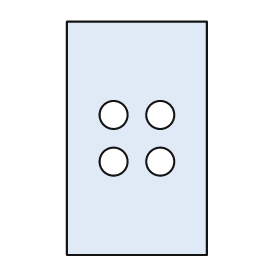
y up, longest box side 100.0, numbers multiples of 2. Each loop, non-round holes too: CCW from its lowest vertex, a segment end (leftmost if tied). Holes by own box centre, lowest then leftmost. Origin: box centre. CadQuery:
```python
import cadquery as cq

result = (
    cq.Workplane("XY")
    .moveTo(-30.0, -50.0)
    .lineTo(30.0, -50.0)
    .lineTo(30.0, 50.0)
    .lineTo(-30.0, 50.0)
    .close()
    .moveTo(-10.0, -10.0)
    .circle(6.0)
    .moveTo(10.0, -10.0)
    .circle(6.0)
    .moveTo(-10.0, 10.0)
    .circle(6.0)
    .moveTo(10.0, 10.0)
    .circle(6.0)
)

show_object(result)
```